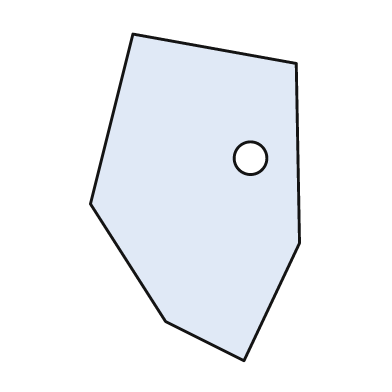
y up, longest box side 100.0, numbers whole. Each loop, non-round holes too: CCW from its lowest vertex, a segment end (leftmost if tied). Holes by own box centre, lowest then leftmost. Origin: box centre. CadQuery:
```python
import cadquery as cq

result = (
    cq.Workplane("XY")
    .moveTo(15.0, -50.0)
    .lineTo(32.0, -14.0)
    .lineTo(31.0, 41.0)
    .lineTo(-19.0, 50.0)
    .lineTo(-32.0, -2.0)
    .lineTo(-9.0, -38.0)
    .close()
    .moveTo(17.0, 12.0)
    .circle(5.0)
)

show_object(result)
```